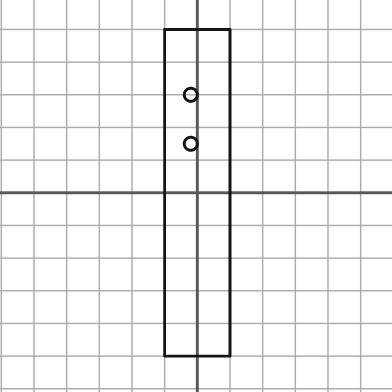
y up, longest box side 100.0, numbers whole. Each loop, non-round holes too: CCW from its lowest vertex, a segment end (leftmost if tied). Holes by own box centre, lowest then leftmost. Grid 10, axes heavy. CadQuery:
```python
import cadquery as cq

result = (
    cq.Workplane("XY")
    .moveTo(-10.0, -50.0)
    .lineTo(10.0, -50.0)
    .lineTo(10.0, 50.0)
    .lineTo(-10.0, 50.0)
    .close()
    .moveTo(-2.0, 15.0)
    .circle(2.0)
    .moveTo(-2.0, 30.0)
    .circle(2.0)
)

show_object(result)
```